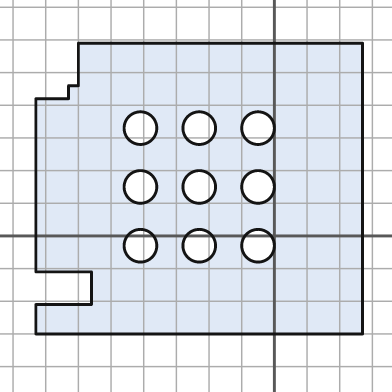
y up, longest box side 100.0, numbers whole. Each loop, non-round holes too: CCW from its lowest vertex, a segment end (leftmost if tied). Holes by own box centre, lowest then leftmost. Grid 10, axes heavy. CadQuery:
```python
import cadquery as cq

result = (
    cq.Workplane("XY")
    .moveTo(-73.0, -30.0)
    .lineTo(27.0, -30.0)
    .lineTo(27.0, 59.0)
    .lineTo(-60.0, 59.0)
    .lineTo(-60.0, 46.0)
    .lineTo(-63.0, 46.0)
    .lineTo(-63.0, 42.0)
    .lineTo(-73.0, 42.0)
    .lineTo(-73.0, -11.0)
    .lineTo(-56.0, -11.0)
    .lineTo(-56.0, -21.0)
    .lineTo(-73.0, -21.0)
    .close()
    .moveTo(-41.0, -3.0)
    .circle(5.0)
    .moveTo(-23.0, -3.0)
    .circle(5.0)
    .moveTo(-5.0, -3.0)
    .circle(5.0)
    .moveTo(-41.0, 15.0)
    .circle(5.0)
    .moveTo(-23.0, 15.0)
    .circle(5.0)
    .moveTo(-5.0, 15.0)
    .circle(5.0)
    .moveTo(-41.0, 33.0)
    .circle(5.0)
    .moveTo(-23.0, 33.0)
    .circle(5.0)
    .moveTo(-5.0, 33.0)
    .circle(5.0)
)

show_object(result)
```